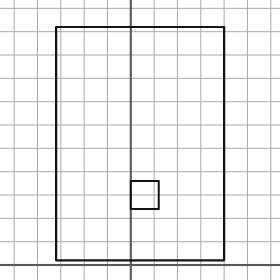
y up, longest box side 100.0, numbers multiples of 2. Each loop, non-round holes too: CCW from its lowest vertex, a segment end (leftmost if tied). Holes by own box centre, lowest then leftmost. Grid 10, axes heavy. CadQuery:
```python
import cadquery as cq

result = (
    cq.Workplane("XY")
    .moveTo(-32.0, 2.0)
    .lineTo(40.0, 2.0)
    .lineTo(40.0, 102.0)
    .lineTo(-32.0, 102.0)
    .close()
    .moveTo(0.0, 24.0)
    .lineTo(12.0, 24.0)
    .lineTo(12.0, 36.0)
    .lineTo(0.0, 36.0)
    .close()
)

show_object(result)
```